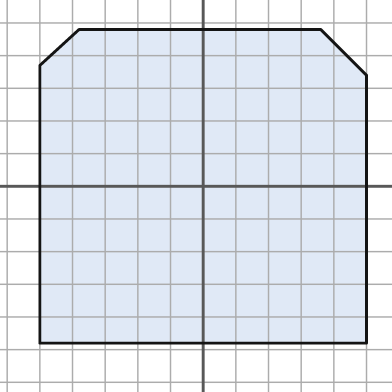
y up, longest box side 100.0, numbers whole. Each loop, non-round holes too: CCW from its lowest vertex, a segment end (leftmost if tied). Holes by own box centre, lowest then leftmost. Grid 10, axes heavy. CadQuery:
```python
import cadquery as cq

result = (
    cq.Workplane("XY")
    .moveTo(-50.0, -48.0)
    .lineTo(50.0, -48.0)
    .lineTo(50.0, 34.0)
    .lineTo(36.0, 48.0)
    .lineTo(-38.0, 48.0)
    .lineTo(-50.0, 37.0)
    .close()
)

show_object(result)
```